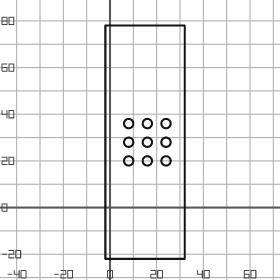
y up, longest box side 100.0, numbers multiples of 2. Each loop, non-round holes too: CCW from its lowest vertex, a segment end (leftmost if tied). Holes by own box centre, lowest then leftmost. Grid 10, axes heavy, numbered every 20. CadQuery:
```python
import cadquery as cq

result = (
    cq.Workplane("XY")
    .moveTo(-2.0, -22.0)
    .lineTo(32.0, -22.0)
    .lineTo(32.0, 78.0)
    .lineTo(-2.0, 78.0)
    .close()
    .moveTo(8.0, 20.0)
    .circle(2.0)
    .moveTo(16.0, 20.0)
    .circle(2.0)
    .moveTo(24.0, 20.0)
    .circle(2.0)
    .moveTo(8.0, 28.0)
    .circle(2.0)
    .moveTo(16.0, 28.0)
    .circle(2.0)
    .moveTo(24.0, 28.0)
    .circle(2.0)
    .moveTo(8.0, 36.0)
    .circle(2.0)
    .moveTo(16.0, 36.0)
    .circle(2.0)
    .moveTo(24.0, 36.0)
    .circle(2.0)
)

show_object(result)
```